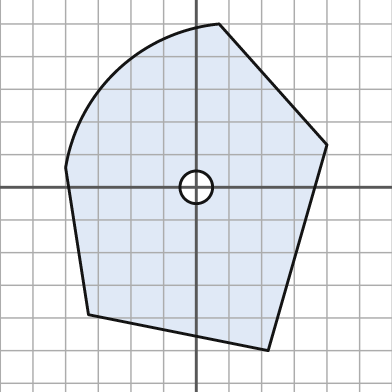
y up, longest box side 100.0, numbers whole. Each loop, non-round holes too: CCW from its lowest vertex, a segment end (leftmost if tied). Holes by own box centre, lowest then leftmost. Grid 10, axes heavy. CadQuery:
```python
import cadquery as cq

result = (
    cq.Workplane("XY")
    .moveTo(22.0, -50.0)
    .lineTo(40.0, 13.0)
    .lineTo(7.0, 50.0)
    .threePointArc((-24.0, 36.0), (-40.0, 6.0))
    .lineTo(-33.0, -39.0)
    .close()
    .moveTo(0.0, 0.0)
    .circle(5.0)
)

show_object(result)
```